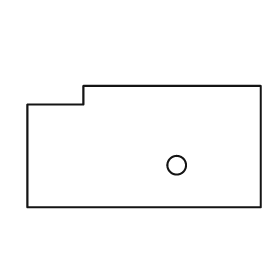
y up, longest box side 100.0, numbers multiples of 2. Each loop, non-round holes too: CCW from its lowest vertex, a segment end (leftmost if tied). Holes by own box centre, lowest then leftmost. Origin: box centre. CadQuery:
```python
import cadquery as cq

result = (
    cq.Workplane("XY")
    .moveTo(-50.0, -26.0)
    .lineTo(50.0, -26.0)
    .lineTo(50.0, 26.0)
    .lineTo(-26.0, 26.0)
    .lineTo(-26.0, 18.0)
    .lineTo(-50.0, 18.0)
    .close()
    .moveTo(14.0, -8.0)
    .circle(4.0)
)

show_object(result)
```